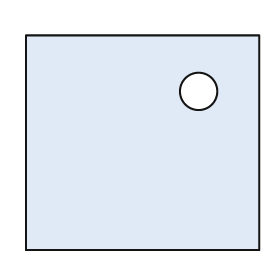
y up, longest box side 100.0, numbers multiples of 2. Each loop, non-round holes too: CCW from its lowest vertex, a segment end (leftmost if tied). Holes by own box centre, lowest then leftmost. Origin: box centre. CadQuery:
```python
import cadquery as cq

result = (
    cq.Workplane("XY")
    .moveTo(-50.0, -46.0)
    .lineTo(50.0, -46.0)
    .lineTo(50.0, 46.0)
    .lineTo(-50.0, 46.0)
    .close()
    .moveTo(24.0, 22.0)
    .circle(8.0)
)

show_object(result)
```